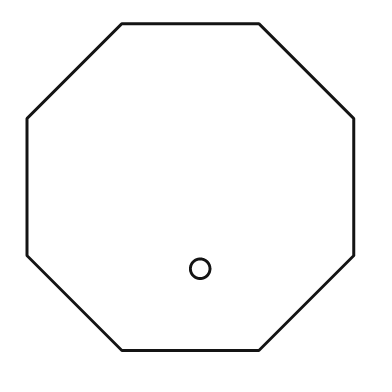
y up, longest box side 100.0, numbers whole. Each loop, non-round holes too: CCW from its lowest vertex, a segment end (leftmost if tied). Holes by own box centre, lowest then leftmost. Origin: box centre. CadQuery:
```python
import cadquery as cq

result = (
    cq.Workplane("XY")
    .moveTo(-21.0, -50.0)
    .lineTo(21.0, -50.0)
    .lineTo(50.0, -21.0)
    .lineTo(50.0, 21.0)
    .lineTo(21.0, 50.0)
    .lineTo(-21.0, 50.0)
    .lineTo(-50.0, 21.0)
    .lineTo(-50.0, -21.0)
    .close()
    .moveTo(3.0, -25.0)
    .circle(3.0)
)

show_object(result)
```